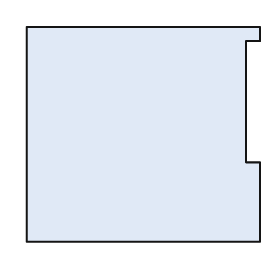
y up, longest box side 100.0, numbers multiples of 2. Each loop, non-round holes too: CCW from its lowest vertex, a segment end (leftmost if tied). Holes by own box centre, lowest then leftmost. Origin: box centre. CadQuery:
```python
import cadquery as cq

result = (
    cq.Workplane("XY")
    .moveTo(-50.0, -46.0)
    .lineTo(50.0, -46.0)
    .lineTo(50.0, -12.0)
    .lineTo(44.0, -12.0)
    .lineTo(44.0, 40.0)
    .lineTo(50.0, 40.0)
    .lineTo(50.0, 46.0)
    .lineTo(-50.0, 46.0)
    .close()
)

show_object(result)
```